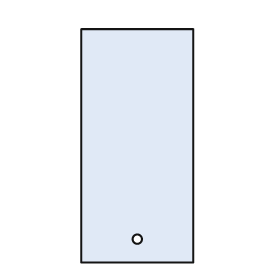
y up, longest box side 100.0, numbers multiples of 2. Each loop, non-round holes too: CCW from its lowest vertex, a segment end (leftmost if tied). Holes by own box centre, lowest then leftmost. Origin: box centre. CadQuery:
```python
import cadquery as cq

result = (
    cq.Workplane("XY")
    .moveTo(-24.0, -50.0)
    .lineTo(24.0, -50.0)
    .lineTo(24.0, 50.0)
    .lineTo(-24.0, 50.0)
    .close()
    .moveTo(0.0, -40.0)
    .circle(2.0)
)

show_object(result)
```